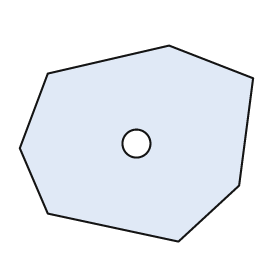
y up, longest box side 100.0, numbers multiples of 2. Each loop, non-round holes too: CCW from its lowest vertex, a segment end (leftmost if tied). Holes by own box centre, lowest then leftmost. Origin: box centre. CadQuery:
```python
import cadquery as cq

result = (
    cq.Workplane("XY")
    .moveTo(18.0, -42.0)
    .lineTo(44.0, -18.0)
    .lineTo(50.0, 28.0)
    .lineTo(14.0, 42.0)
    .lineTo(-38.0, 30.0)
    .lineTo(-50.0, -2.0)
    .lineTo(-38.0, -30.0)
    .close()
    .moveTo(0.0, 0.0)
    .circle(6.0)
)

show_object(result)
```